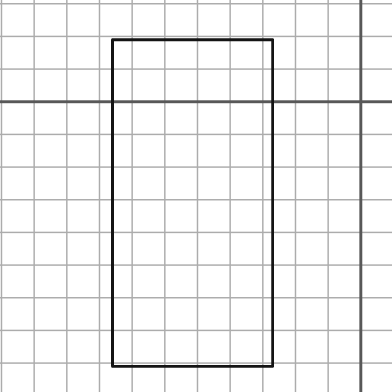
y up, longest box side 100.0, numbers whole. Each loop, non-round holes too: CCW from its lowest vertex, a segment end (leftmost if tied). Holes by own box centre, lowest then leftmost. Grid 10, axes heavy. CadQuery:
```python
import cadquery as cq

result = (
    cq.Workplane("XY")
    .moveTo(-76.0, -81.0)
    .lineTo(-27.0, -81.0)
    .lineTo(-27.0, 19.0)
    .lineTo(-76.0, 19.0)
    .close()
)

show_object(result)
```